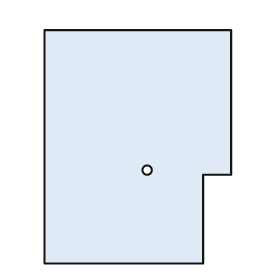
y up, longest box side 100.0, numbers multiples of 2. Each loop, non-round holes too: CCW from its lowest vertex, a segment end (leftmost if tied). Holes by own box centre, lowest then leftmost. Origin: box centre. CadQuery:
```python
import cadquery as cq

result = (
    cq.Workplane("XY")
    .moveTo(-40.0, -50.0)
    .lineTo(28.0, -50.0)
    .lineTo(28.0, -12.0)
    .lineTo(40.0, -12.0)
    .lineTo(40.0, 50.0)
    .lineTo(-40.0, 50.0)
    .close()
    .moveTo(4.0, -10.0)
    .circle(2.0)
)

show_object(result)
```